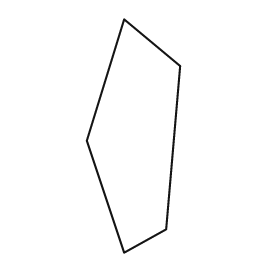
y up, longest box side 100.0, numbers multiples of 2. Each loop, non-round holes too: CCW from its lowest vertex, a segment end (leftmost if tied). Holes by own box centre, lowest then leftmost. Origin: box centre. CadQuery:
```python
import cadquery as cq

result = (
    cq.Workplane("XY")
    .moveTo(-4.0, -50.0)
    .lineTo(14.0, -40.0)
    .lineTo(20.0, 30.0)
    .lineTo(-4.0, 50.0)
    .lineTo(-20.0, -2.0)
    .close()
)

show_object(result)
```